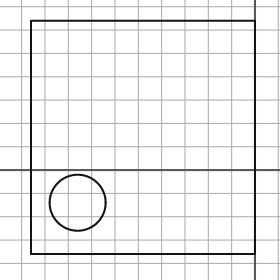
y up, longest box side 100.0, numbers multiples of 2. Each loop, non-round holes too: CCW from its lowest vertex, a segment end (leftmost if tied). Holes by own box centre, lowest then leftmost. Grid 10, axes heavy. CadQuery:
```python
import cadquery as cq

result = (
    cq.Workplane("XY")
    .moveTo(-96.0, -36.0)
    .lineTo(0.0, -36.0)
    .lineTo(0.0, 64.0)
    .lineTo(-96.0, 64.0)
    .close()
    .moveTo(-76.0, -14.0)
    .circle(12.0)
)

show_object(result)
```